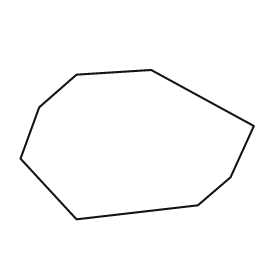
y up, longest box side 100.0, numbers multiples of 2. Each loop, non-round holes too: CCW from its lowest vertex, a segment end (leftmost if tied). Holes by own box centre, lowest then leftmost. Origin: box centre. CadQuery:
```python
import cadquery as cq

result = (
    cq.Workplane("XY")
    .moveTo(-26.0, -32.0)
    .lineTo(26.0, -26.0)
    .lineTo(40.0, -14.0)
    .lineTo(50.0, 8.0)
    .lineTo(6.0, 32.0)
    .lineTo(-26.0, 30.0)
    .lineTo(-42.0, 16.0)
    .lineTo(-50.0, -6.0)
    .close()
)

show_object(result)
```